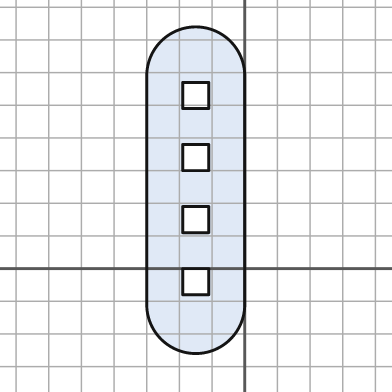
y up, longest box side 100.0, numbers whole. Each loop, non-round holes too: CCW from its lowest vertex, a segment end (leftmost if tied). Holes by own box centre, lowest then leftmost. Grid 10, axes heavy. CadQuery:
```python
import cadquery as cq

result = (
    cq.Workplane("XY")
    .moveTo(-30.0, -11.0)
    .threePointArc((-15.0, -26.0), (0.0, -11.0))
    .lineTo(0.0, 59.0)
    .threePointArc((-15.0, 74.0), (-30.0, 59.0))
    .close()
    .moveTo(-19.0, -8.0)
    .lineTo(-11.0, -8.0)
    .lineTo(-11.0, 0.0)
    .lineTo(-19.0, 0.0)
    .close()
    .moveTo(-19.0, 11.0)
    .lineTo(-11.0, 11.0)
    .lineTo(-11.0, 19.0)
    .lineTo(-19.0, 19.0)
    .close()
    .moveTo(-19.0, 30.0)
    .lineTo(-11.0, 30.0)
    .lineTo(-11.0, 38.0)
    .lineTo(-19.0, 38.0)
    .close()
    .moveTo(-19.0, 49.0)
    .lineTo(-11.0, 49.0)
    .lineTo(-11.0, 57.0)
    .lineTo(-19.0, 57.0)
    .close()
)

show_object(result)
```